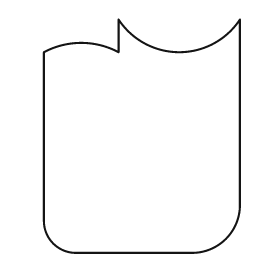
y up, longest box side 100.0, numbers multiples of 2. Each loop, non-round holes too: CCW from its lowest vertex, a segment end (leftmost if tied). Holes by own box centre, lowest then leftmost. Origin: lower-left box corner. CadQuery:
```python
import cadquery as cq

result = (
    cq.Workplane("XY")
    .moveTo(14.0, 0.0)
    .lineTo(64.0, 0.0)
    .threePointArc((78.0, 6.0), (84.0, 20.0))
    .lineTo(84.0, 100.0)
    .threePointArc((58.0, 86.0), (32.0, 100.0))
    .lineTo(32.0, 86.0)
    .threePointArc((16.0, 90.0), (0.0, 86.0))
    .lineTo(0.0, 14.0)
    .threePointArc((4.0, 4.0), (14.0, 0.0))
    .close()
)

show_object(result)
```